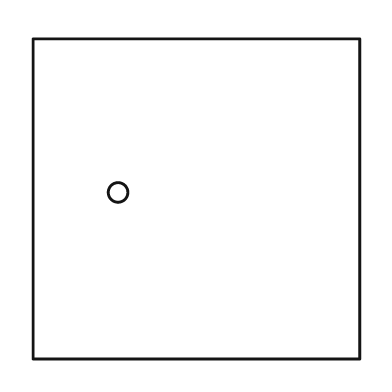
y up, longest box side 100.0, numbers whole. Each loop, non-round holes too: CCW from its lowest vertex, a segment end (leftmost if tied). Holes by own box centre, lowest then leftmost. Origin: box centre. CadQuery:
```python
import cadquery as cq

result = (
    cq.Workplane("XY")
    .moveTo(-50.0, -49.0)
    .lineTo(50.0, -49.0)
    .lineTo(50.0, 49.0)
    .lineTo(-50.0, 49.0)
    .close()
    .moveTo(-24.0, 2.0)
    .circle(3.0)
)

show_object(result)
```